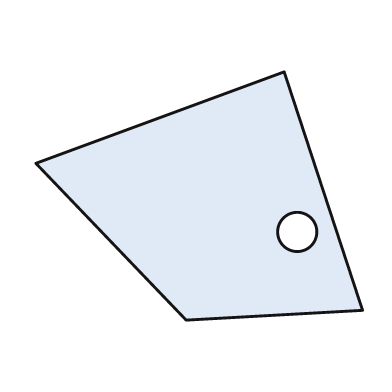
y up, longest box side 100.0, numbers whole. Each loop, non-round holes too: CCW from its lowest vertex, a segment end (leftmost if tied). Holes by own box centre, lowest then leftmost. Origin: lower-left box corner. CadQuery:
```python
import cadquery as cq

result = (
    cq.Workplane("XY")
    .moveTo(46.0, 0.0)
    .lineTo(100.0, 3.0)
    .lineTo(76.0, 76.0)
    .lineTo(0.0, 48.0)
    .close()
    .moveTo(80.0, 27.0)
    .circle(6.0)
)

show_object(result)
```